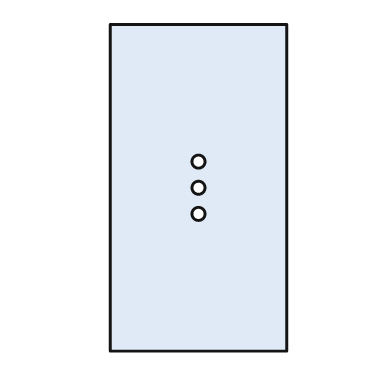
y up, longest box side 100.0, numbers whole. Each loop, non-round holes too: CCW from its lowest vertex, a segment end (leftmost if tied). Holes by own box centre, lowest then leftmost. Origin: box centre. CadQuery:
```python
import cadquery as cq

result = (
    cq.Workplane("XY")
    .moveTo(-27.0, -50.0)
    .lineTo(27.0, -50.0)
    .lineTo(27.0, 50.0)
    .lineTo(-27.0, 50.0)
    .close()
    .moveTo(0.0, -8.0)
    .circle(2.0)
    .moveTo(0.0, 0.0)
    .circle(2.0)
    .moveTo(0.0, 8.0)
    .circle(2.0)
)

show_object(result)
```